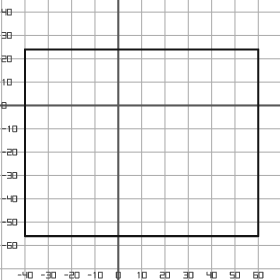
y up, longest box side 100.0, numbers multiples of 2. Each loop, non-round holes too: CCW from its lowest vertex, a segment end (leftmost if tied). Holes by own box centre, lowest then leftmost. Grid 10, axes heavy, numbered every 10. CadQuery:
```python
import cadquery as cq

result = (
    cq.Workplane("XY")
    .moveTo(-40.0, -56.0)
    .lineTo(60.0, -56.0)
    .lineTo(60.0, 24.0)
    .lineTo(-40.0, 24.0)
    .close()
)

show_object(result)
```